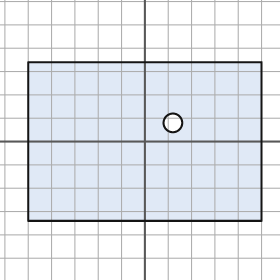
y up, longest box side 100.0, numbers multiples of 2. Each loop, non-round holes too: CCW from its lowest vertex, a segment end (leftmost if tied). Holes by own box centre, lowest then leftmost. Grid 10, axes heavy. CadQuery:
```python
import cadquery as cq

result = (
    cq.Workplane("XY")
    .moveTo(-50.0, -34.0)
    .lineTo(50.0, -34.0)
    .lineTo(50.0, 34.0)
    .lineTo(-50.0, 34.0)
    .close()
    .moveTo(12.0, 8.0)
    .circle(4.0)
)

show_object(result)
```